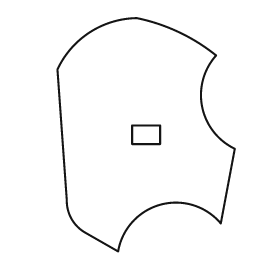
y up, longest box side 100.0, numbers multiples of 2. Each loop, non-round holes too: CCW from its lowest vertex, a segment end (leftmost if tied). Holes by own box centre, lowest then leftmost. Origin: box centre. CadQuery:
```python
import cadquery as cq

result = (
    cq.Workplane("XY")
    .moveTo(-12.0, -50.0)
    .threePointArc((6.0, -30.0), (32.0, -38.0))
    .lineTo(38.0, -6.0)
    .threePointArc((24.0, 12.0), (30.0, 34.0))
    .threePointArc((14.0, 44.0), (-4.0, 50.0))
    .threePointArc((-24.0, 44.0), (-38.0, 28.0))
    .lineTo(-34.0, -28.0)
    .threePointArc((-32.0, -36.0), (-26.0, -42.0))
    .close()
    .moveTo(-6.0, -4.0)
    .lineTo(6.0, -4.0)
    .lineTo(6.0, 4.0)
    .lineTo(-6.0, 4.0)
    .close()
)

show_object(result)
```